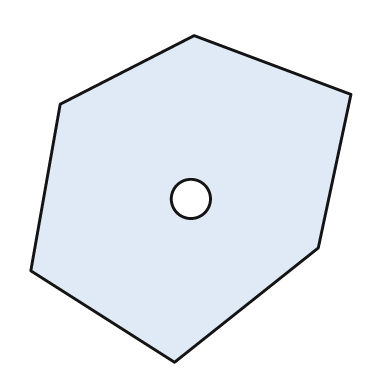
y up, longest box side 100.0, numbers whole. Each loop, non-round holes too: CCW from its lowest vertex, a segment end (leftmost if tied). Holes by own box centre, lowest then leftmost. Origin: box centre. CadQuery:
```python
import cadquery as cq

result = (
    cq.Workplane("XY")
    .moveTo(-5.0, -50.0)
    .lineTo(39.0, -15.0)
    .lineTo(49.0, 32.0)
    .lineTo(1.0, 50.0)
    .lineTo(-40.0, 29.0)
    .lineTo(-49.0, -22.0)
    .close()
    .moveTo(0.0, 0.0)
    .circle(6.0)
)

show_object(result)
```